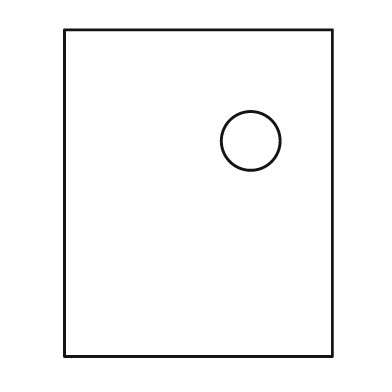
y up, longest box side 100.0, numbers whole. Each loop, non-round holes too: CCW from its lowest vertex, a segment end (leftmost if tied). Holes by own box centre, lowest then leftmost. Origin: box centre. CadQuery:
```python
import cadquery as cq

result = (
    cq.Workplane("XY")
    .moveTo(-41.0, -50.0)
    .lineTo(41.0, -50.0)
    .lineTo(41.0, 50.0)
    .lineTo(-41.0, 50.0)
    .close()
    .moveTo(16.0, 16.0)
    .circle(9.0)
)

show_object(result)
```